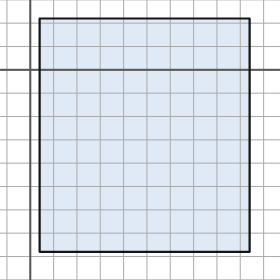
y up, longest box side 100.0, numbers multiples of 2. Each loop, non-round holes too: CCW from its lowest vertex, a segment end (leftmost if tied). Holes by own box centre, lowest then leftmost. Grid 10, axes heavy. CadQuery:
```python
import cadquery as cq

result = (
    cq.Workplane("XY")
    .moveTo(4.0, -78.0)
    .lineTo(94.0, -78.0)
    .lineTo(94.0, 22.0)
    .lineTo(4.0, 22.0)
    .close()
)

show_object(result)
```